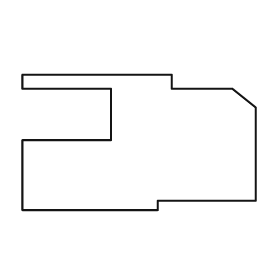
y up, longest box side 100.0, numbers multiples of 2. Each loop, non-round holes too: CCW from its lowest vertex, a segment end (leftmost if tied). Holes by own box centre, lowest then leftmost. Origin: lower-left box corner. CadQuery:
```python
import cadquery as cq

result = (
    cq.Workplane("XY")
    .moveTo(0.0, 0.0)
    .lineTo(58.0, 0.0)
    .lineTo(58.0, 4.0)
    .lineTo(100.0, 4.0)
    .lineTo(100.0, 44.0)
    .lineTo(90.0, 52.0)
    .lineTo(64.0, 52.0)
    .lineTo(64.0, 58.0)
    .lineTo(0.0, 58.0)
    .lineTo(0.0, 52.0)
    .lineTo(38.0, 52.0)
    .lineTo(38.0, 30.0)
    .lineTo(0.0, 30.0)
    .close()
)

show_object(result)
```